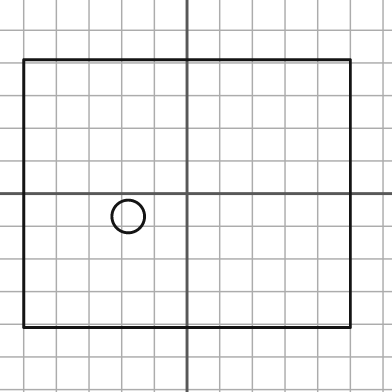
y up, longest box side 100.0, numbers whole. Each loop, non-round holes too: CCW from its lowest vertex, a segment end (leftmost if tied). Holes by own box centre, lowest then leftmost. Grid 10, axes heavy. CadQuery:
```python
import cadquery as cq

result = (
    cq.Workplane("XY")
    .moveTo(-50.0, -41.0)
    .lineTo(50.0, -41.0)
    .lineTo(50.0, 41.0)
    .lineTo(-50.0, 41.0)
    .close()
    .moveTo(-18.0, -7.0)
    .circle(5.0)
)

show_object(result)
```